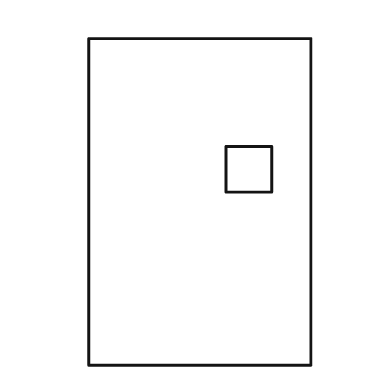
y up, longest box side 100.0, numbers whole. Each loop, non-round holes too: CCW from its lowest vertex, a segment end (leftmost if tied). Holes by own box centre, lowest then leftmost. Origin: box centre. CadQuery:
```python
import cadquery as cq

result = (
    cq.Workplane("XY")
    .moveTo(-34.0, -50.0)
    .lineTo(34.0, -50.0)
    .lineTo(34.0, 50.0)
    .lineTo(-34.0, 50.0)
    .close()
    .moveTo(8.0, 3.0)
    .lineTo(22.0, 3.0)
    .lineTo(22.0, 17.0)
    .lineTo(8.0, 17.0)
    .close()
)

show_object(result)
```